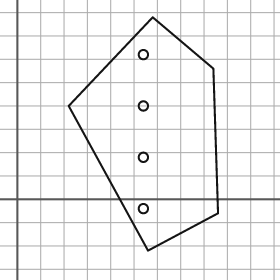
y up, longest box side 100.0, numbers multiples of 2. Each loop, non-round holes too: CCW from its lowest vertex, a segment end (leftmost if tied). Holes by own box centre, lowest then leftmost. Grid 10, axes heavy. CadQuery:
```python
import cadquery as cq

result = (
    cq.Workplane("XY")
    .moveTo(56.0, -22.0)
    .lineTo(86.0, -6.0)
    .lineTo(84.0, 56.0)
    .lineTo(58.0, 78.0)
    .lineTo(22.0, 40.0)
    .close()
    .moveTo(54.0, -4.0)
    .circle(2.0)
    .moveTo(54.0, 18.0)
    .circle(2.0)
    .moveTo(54.0, 40.0)
    .circle(2.0)
    .moveTo(54.0, 62.0)
    .circle(2.0)
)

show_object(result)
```